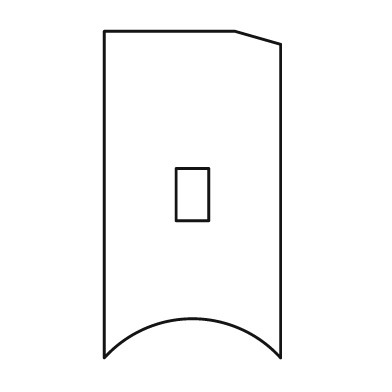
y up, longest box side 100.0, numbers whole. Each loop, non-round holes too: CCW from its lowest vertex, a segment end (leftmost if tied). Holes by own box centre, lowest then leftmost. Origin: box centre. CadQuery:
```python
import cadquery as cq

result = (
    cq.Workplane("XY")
    .moveTo(-27.0, -50.0)
    .threePointArc((0.0, -38.0), (27.0, -50.0))
    .lineTo(27.0, 46.0)
    .lineTo(13.0, 50.0)
    .lineTo(-27.0, 50.0)
    .close()
    .moveTo(-5.0, -8.0)
    .lineTo(5.0, -8.0)
    .lineTo(5.0, 8.0)
    .lineTo(-5.0, 8.0)
    .close()
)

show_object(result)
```